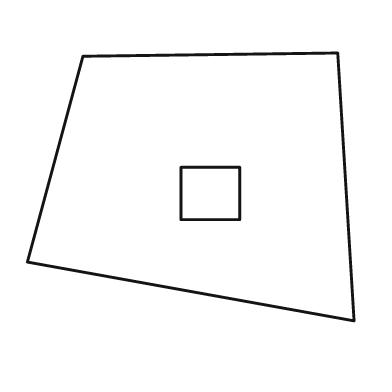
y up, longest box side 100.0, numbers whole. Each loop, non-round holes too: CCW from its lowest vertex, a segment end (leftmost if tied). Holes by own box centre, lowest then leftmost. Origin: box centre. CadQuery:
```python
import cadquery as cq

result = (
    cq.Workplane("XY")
    .moveTo(50.0, -41.0)
    .lineTo(45.0, 41.0)
    .lineTo(-33.0, 40.0)
    .lineTo(-50.0, -23.0)
    .close()
    .moveTo(-3.0, -10.0)
    .lineTo(15.0, -10.0)
    .lineTo(15.0, 6.0)
    .lineTo(-3.0, 6.0)
    .close()
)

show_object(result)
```